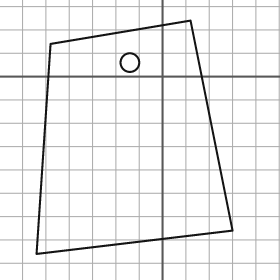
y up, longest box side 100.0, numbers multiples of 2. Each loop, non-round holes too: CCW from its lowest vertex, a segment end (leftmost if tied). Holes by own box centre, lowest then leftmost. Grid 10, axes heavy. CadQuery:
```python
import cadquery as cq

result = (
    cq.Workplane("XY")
    .moveTo(-54.0, -76.0)
    .lineTo(30.0, -66.0)
    .lineTo(12.0, 24.0)
    .lineTo(-48.0, 14.0)
    .close()
    .moveTo(-14.0, 6.0)
    .circle(4.0)
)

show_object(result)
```